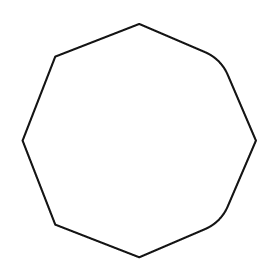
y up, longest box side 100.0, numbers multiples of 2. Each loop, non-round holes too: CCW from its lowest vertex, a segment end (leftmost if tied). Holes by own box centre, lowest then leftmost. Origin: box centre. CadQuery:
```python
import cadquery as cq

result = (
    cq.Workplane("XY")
    .moveTo(0.0, -50.0)
    .lineTo(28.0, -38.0)
    .threePointArc((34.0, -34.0), (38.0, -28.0))
    .lineTo(50.0, 0.0)
    .lineTo(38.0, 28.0)
    .threePointArc((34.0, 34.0), (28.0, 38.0))
    .lineTo(0.0, 50.0)
    .lineTo(-36.0, 36.0)
    .lineTo(-50.0, 0.0)
    .lineTo(-36.0, -36.0)
    .close()
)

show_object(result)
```